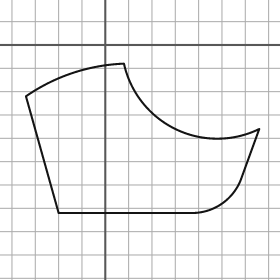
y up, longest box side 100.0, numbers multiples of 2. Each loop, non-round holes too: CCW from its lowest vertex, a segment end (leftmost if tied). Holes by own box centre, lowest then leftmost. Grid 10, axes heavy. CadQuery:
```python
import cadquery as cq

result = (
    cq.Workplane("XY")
    .moveTo(-20.0, -72.0)
    .lineTo(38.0, -72.0)
    .threePointArc((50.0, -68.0), (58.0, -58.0))
    .lineTo(66.0, -36.0)
    .threePointArc((30.0, -36.0), (8.0, -8.0))
    .threePointArc((-14.0, -12.0), (-34.0, -22.0))
    .close()
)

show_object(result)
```